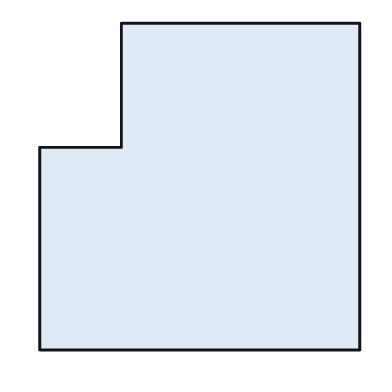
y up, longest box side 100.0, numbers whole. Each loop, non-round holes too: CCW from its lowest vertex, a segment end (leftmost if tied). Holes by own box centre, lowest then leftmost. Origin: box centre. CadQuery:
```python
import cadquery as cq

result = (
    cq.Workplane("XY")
    .moveTo(-49.0, -50.0)
    .lineTo(49.0, -50.0)
    .lineTo(49.0, 50.0)
    .lineTo(-24.0, 50.0)
    .lineTo(-24.0, 12.0)
    .lineTo(-49.0, 12.0)
    .close()
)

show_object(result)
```